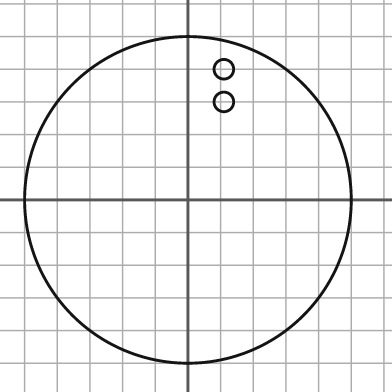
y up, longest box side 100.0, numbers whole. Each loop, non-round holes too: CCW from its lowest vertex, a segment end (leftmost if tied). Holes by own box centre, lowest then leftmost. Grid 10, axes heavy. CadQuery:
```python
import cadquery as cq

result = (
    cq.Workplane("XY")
    .moveTo(0.0, 0.0)
    .circle(50.0)
    .moveTo(11.0, 30.0)
    .circle(3.0)
    .moveTo(11.0, 40.0)
    .circle(3.0)
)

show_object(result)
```